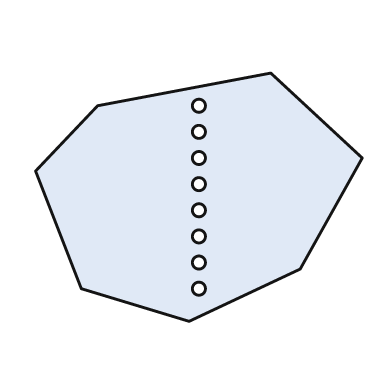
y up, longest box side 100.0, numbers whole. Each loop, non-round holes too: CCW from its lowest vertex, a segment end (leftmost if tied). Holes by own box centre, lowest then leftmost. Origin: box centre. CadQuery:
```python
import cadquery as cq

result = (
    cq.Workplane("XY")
    .moveTo(-3.0, -38.0)
    .lineTo(31.0, -22.0)
    .lineTo(50.0, 12.0)
    .lineTo(22.0, 38.0)
    .lineTo(-31.0, 28.0)
    .lineTo(-50.0, 8.0)
    .lineTo(-36.0, -28.0)
    .close()
    .moveTo(0.0, -28.0)
    .circle(2.0)
    .moveTo(0.0, -20.0)
    .circle(2.0)
    .moveTo(0.0, -12.0)
    .circle(2.0)
    .moveTo(0.0, -4.0)
    .circle(2.0)
    .moveTo(0.0, 4.0)
    .circle(2.0)
    .moveTo(0.0, 12.0)
    .circle(2.0)
    .moveTo(0.0, 20.0)
    .circle(2.0)
    .moveTo(0.0, 28.0)
    .circle(2.0)
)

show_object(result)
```